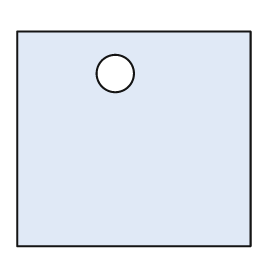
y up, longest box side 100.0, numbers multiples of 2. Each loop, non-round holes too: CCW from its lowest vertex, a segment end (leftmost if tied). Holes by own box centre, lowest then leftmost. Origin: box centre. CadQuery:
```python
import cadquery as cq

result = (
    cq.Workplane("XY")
    .moveTo(-50.0, -46.0)
    .lineTo(50.0, -46.0)
    .lineTo(50.0, 46.0)
    .lineTo(-50.0, 46.0)
    .close()
    .moveTo(-8.0, 28.0)
    .circle(8.0)
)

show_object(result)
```